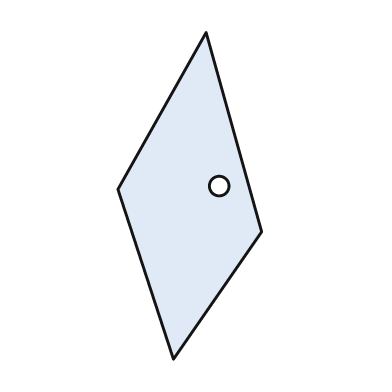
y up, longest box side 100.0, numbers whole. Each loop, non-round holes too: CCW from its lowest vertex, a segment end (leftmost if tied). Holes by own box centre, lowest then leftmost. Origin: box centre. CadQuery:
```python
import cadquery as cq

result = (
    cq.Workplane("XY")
    .moveTo(-5.0, -50.0)
    .lineTo(22.0, -11.0)
    .lineTo(5.0, 50.0)
    .lineTo(-22.0, 2.0)
    .close()
    .moveTo(9.0, 3.0)
    .circle(3.0)
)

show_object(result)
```